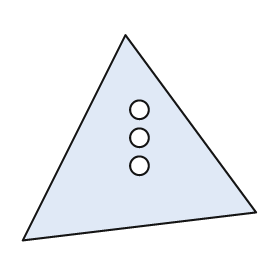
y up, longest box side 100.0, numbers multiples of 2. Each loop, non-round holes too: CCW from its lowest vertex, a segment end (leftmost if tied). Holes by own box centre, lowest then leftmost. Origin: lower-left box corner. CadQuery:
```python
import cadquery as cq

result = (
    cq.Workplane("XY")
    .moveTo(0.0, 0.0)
    .lineTo(100.0, 12.0)
    .lineTo(44.0, 88.0)
    .close()
    .moveTo(50.0, 32.0)
    .circle(4.0)
    .moveTo(50.0, 44.0)
    .circle(4.0)
    .moveTo(50.0, 56.0)
    .circle(4.0)
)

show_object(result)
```